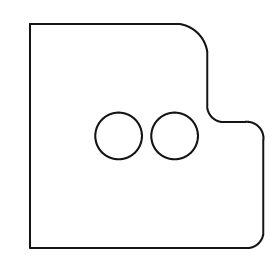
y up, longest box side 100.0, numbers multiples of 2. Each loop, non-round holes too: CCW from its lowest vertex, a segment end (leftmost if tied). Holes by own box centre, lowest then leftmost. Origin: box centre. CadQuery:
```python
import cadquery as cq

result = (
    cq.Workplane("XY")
    .moveTo(-50.0, -48.0)
    .lineTo(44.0, -48.0)
    .threePointArc((48.0, -46.0), (50.0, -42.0))
    .lineTo(50.0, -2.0)
    .threePointArc((48.0, 4.0), (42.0, 6.0))
    .lineTo(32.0, 6.0)
    .threePointArc((28.0, 8.0), (26.0, 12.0))
    .lineTo(26.0, 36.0)
    .threePointArc((22.0, 44.0), (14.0, 48.0))
    .lineTo(-50.0, 48.0)
    .close()
    .moveTo(-12.0, 0.0)
    .circle(10.0)
    .moveTo(12.0, 0.0)
    .circle(10.0)
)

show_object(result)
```